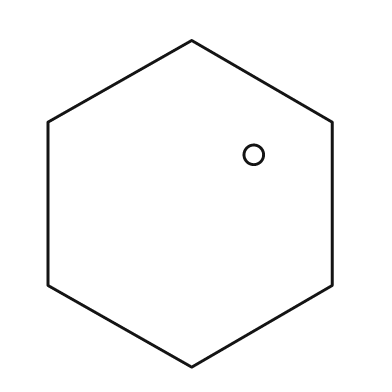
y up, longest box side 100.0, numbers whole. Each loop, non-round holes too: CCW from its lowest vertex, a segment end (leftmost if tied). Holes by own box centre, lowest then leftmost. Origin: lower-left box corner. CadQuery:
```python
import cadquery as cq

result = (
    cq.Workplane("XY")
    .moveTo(44.0, 0.0)
    .lineTo(87.0, 25.0)
    .lineTo(87.0, 75.0)
    .lineTo(44.0, 100.0)
    .lineTo(0.0, 75.0)
    .lineTo(0.0, 25.0)
    .close()
    .moveTo(63.0, 65.0)
    .circle(3.0)
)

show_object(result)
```